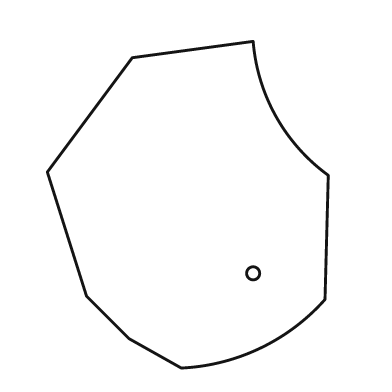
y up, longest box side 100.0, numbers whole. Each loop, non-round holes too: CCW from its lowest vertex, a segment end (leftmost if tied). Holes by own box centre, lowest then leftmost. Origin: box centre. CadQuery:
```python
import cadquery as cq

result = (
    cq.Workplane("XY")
    .moveTo(-2.0, -50.0)
    .threePointArc((22.0, -44.0), (42.0, -29.0))
    .lineTo(43.0, 9.0)
    .threePointArc((27.0, 27.0), (20.0, 50.0))
    .lineTo(-17.0, 45.0)
    .lineTo(-43.0, 10.0)
    .lineTo(-31.0, -28.0)
    .lineTo(-18.0, -41.0)
    .close()
    .moveTo(20.0, -21.0)
    .circle(2.0)
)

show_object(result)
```